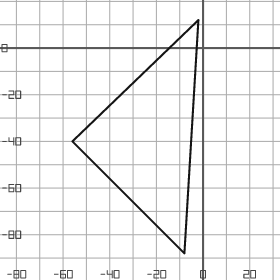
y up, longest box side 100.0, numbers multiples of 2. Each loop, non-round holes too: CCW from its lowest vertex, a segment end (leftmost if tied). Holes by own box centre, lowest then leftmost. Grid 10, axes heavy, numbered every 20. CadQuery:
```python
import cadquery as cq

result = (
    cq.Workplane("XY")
    .moveTo(-8.0, -88.0)
    .lineTo(-2.0, 12.0)
    .lineTo(-56.0, -40.0)
    .close()
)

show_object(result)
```